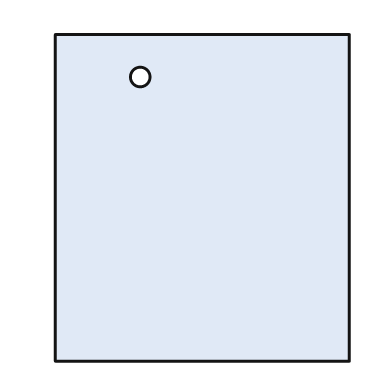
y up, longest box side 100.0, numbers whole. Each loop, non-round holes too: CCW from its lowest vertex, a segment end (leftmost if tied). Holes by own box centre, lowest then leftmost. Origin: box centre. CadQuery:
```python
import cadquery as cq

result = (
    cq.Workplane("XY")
    .moveTo(-45.0, -50.0)
    .lineTo(45.0, -50.0)
    .lineTo(45.0, 50.0)
    .lineTo(-45.0, 50.0)
    .close()
    .moveTo(-19.0, 37.0)
    .circle(3.0)
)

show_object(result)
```